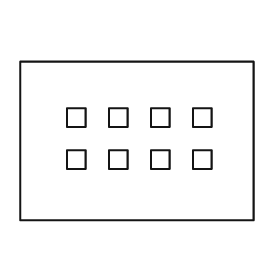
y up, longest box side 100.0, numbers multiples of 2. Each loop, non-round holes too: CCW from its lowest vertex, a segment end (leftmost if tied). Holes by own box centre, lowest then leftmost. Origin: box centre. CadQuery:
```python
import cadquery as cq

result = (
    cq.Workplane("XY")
    .moveTo(-50.0, -34.0)
    .lineTo(50.0, -34.0)
    .lineTo(50.0, 34.0)
    .lineTo(-50.0, 34.0)
    .close()
    .moveTo(-30.0, -12.0)
    .lineTo(-22.0, -12.0)
    .lineTo(-22.0, -4.0)
    .lineTo(-30.0, -4.0)
    .close()
    .moveTo(-12.0, -12.0)
    .lineTo(-4.0, -12.0)
    .lineTo(-4.0, -4.0)
    .lineTo(-12.0, -4.0)
    .close()
    .moveTo(6.0, -12.0)
    .lineTo(14.0, -12.0)
    .lineTo(14.0, -4.0)
    .lineTo(6.0, -4.0)
    .close()
    .moveTo(24.0, -12.0)
    .lineTo(32.0, -12.0)
    .lineTo(32.0, -4.0)
    .lineTo(24.0, -4.0)
    .close()
    .moveTo(-30.0, 6.0)
    .lineTo(-22.0, 6.0)
    .lineTo(-22.0, 14.0)
    .lineTo(-30.0, 14.0)
    .close()
    .moveTo(-12.0, 6.0)
    .lineTo(-4.0, 6.0)
    .lineTo(-4.0, 14.0)
    .lineTo(-12.0, 14.0)
    .close()
    .moveTo(6.0, 6.0)
    .lineTo(14.0, 6.0)
    .lineTo(14.0, 14.0)
    .lineTo(6.0, 14.0)
    .close()
    .moveTo(24.0, 6.0)
    .lineTo(32.0, 6.0)
    .lineTo(32.0, 14.0)
    .lineTo(24.0, 14.0)
    .close()
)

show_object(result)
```